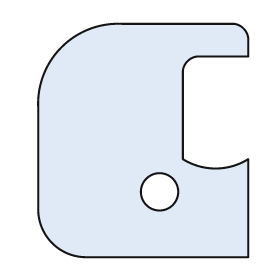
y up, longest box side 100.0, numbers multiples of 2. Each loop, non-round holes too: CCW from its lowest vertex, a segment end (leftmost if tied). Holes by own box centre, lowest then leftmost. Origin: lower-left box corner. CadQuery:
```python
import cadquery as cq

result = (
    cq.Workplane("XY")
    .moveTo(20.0, 0.0)
    .lineTo(90.0, 0.0)
    .lineTo(90.0, 42.0)
    .threePointArc((76.0, 38.0), (62.0, 42.0))
    .lineTo(62.0, 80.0)
    .threePointArc((64.0, 84.0), (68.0, 86.0))
    .lineTo(90.0, 86.0)
    .lineTo(90.0, 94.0)
    .threePointArc((88.0, 98.0), (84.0, 100.0))
    .lineTo(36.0, 100.0)
    .threePointArc((10.0, 90.0), (0.0, 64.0))
    .lineTo(0.0, 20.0)
    .threePointArc((6.0, 6.0), (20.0, 0.0))
    .close()
    .moveTo(52.0, 28.0)
    .circle(8.0)
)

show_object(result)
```